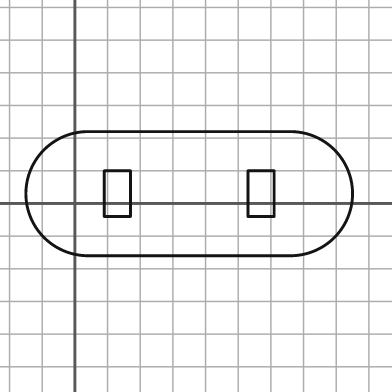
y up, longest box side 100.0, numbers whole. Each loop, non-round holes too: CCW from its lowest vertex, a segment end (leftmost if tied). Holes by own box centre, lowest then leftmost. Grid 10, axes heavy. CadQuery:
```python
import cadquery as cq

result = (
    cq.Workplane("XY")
    .moveTo(4.0, -16.0)
    .lineTo(66.0, -16.0)
    .threePointArc((85.0, 3.0), (66.0, 22.0))
    .lineTo(4.0, 22.0)
    .threePointArc((-15.0, 3.0), (4.0, -16.0))
    .close()
    .moveTo(9.0, -4.0)
    .lineTo(17.0, -4.0)
    .lineTo(17.0, 10.0)
    .lineTo(9.0, 10.0)
    .close()
    .moveTo(53.0, -4.0)
    .lineTo(61.0, -4.0)
    .lineTo(61.0, 10.0)
    .lineTo(53.0, 10.0)
    .close()
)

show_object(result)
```